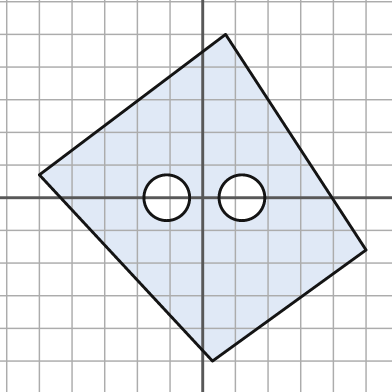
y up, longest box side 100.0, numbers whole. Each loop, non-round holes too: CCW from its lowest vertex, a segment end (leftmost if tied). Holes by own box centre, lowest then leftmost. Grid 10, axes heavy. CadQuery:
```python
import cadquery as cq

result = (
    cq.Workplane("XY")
    .moveTo(3.0, -50.0)
    .lineTo(50.0, -16.0)
    .lineTo(7.0, 50.0)
    .lineTo(-50.0, 7.0)
    .close()
    .moveTo(-11.0, 0.0)
    .circle(7.0)
    .moveTo(12.0, 0.0)
    .circle(7.0)
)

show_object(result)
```